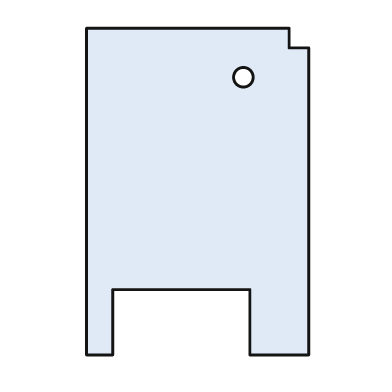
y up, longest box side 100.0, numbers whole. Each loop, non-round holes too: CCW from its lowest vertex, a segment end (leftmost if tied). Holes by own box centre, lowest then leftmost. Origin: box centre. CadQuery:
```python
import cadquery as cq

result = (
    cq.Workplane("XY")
    .moveTo(-34.0, -50.0)
    .lineTo(-26.0, -50.0)
    .lineTo(-26.0, -30.0)
    .lineTo(16.0, -30.0)
    .lineTo(16.0, -50.0)
    .lineTo(34.0, -50.0)
    .lineTo(34.0, 44.0)
    .lineTo(28.0, 44.0)
    .lineTo(28.0, 50.0)
    .lineTo(-34.0, 50.0)
    .close()
    .moveTo(14.0, 35.0)
    .circle(3.0)
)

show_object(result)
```